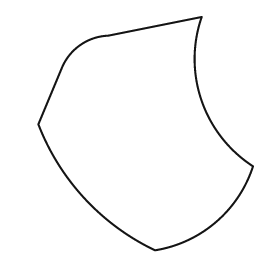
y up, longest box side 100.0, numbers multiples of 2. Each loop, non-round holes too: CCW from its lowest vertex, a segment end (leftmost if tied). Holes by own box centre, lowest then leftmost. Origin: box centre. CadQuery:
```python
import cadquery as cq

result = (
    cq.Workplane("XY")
    .moveTo(4.0, -50.0)
    .threePointArc((30.0, -38.0), (46.0, -14.0))
    .threePointArc((24.0, 14.0), (24.0, 50.0))
    .lineTo(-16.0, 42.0)
    .threePointArc((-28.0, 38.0), (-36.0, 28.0))
    .lineTo(-46.0, 4.0)
    .threePointArc((-26.0, -28.0), (4.0, -50.0))
    .close()
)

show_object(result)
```